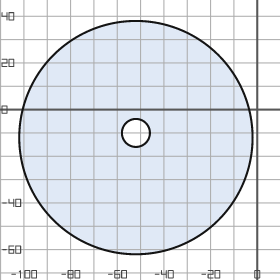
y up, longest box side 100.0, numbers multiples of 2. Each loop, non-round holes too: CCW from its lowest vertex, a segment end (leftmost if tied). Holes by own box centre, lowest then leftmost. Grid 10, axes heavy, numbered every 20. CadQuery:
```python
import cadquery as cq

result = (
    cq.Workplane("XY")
    .moveTo(-52.0, -12.0)
    .circle(50.0)
    .moveTo(-52.0, -10.0)
    .circle(6.0)
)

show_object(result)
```